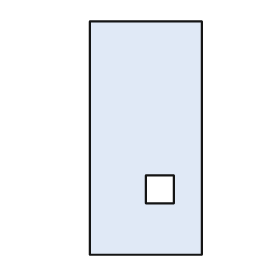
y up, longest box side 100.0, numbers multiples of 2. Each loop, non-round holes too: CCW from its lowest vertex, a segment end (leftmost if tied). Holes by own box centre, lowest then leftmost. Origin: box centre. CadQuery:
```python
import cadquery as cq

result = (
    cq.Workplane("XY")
    .moveTo(-24.0, -50.0)
    .lineTo(24.0, -50.0)
    .lineTo(24.0, 50.0)
    .lineTo(-24.0, 50.0)
    .close()
    .moveTo(0.0, -28.0)
    .lineTo(12.0, -28.0)
    .lineTo(12.0, -16.0)
    .lineTo(0.0, -16.0)
    .close()
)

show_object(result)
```